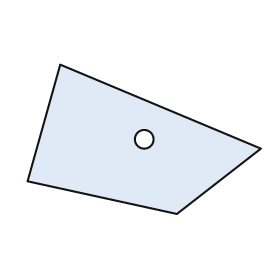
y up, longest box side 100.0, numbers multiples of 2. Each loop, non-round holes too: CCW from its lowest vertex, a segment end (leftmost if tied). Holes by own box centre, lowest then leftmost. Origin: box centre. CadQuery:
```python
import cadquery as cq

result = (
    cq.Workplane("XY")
    .moveTo(14.0, -32.0)
    .lineTo(50.0, -4.0)
    .lineTo(-36.0, 32.0)
    .lineTo(-50.0, -18.0)
    .close()
    .moveTo(0.0, 0.0)
    .circle(4.0)
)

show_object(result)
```